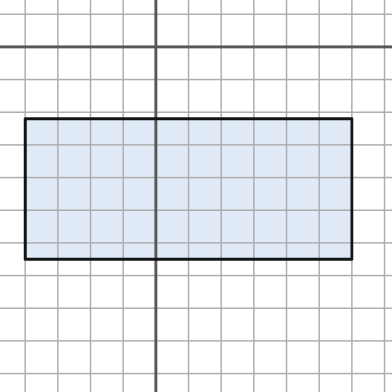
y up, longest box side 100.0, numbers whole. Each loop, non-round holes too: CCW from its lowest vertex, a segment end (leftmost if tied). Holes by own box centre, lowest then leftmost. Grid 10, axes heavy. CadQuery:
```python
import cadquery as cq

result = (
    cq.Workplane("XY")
    .moveTo(-40.0, -65.0)
    .lineTo(60.0, -65.0)
    .lineTo(60.0, -22.0)
    .lineTo(-40.0, -22.0)
    .close()
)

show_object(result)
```